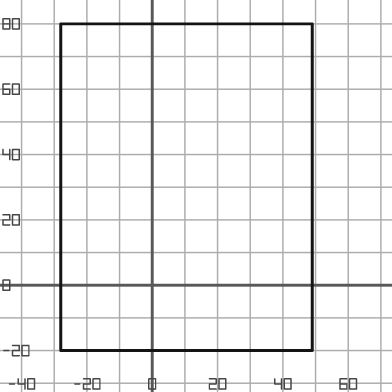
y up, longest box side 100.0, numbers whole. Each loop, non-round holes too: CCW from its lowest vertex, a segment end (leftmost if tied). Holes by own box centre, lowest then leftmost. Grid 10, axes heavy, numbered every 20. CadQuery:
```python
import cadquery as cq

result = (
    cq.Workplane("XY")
    .moveTo(-28.0, -20.0)
    .lineTo(49.0, -20.0)
    .lineTo(49.0, 80.0)
    .lineTo(-28.0, 80.0)
    .close()
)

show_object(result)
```